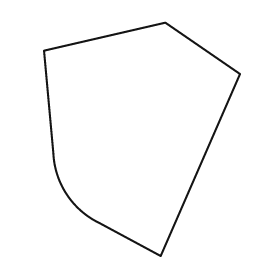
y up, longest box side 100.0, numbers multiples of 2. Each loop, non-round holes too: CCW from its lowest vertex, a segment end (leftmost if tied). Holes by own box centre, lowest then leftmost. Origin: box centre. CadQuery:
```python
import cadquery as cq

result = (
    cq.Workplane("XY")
    .moveTo(8.0, -50.0)
    .lineTo(42.0, 28.0)
    .lineTo(10.0, 50.0)
    .lineTo(-42.0, 38.0)
    .lineTo(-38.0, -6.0)
    .threePointArc((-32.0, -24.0), (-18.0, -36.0))
    .close()
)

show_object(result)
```